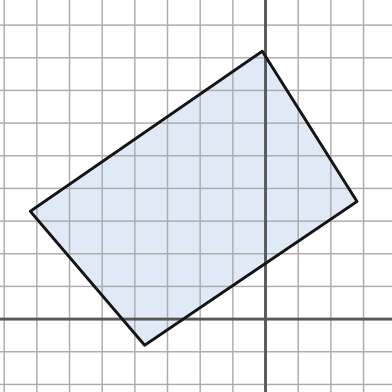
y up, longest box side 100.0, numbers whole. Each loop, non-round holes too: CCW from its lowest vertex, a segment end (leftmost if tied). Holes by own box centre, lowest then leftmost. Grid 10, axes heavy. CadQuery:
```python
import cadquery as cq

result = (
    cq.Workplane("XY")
    .moveTo(-37.0, -8.0)
    .lineTo(28.0, 36.0)
    .lineTo(-1.0, 82.0)
    .lineTo(-72.0, 33.0)
    .close()
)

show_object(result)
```